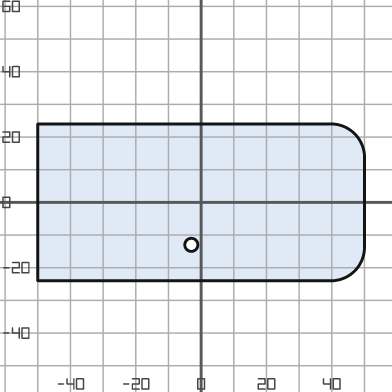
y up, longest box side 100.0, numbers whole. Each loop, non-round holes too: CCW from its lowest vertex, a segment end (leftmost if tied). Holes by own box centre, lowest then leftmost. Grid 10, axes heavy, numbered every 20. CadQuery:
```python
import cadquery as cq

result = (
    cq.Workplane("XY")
    .moveTo(-50.0, -24.0)
    .lineTo(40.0, -24.0)
    .threePointArc((47.0, -21.0), (50.0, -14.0))
    .lineTo(50.0, 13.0)
    .threePointArc((47.0, 21.0), (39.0, 24.0))
    .lineTo(-50.0, 24.0)
    .close()
    .moveTo(-3.0, -13.0)
    .circle(2.0)
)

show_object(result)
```